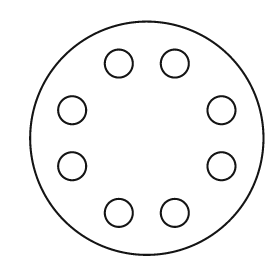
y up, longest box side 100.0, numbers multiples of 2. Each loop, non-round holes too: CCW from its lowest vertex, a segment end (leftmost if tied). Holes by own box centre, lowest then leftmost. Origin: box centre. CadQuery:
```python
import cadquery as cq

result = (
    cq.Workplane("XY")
    .moveTo(0.0, 0.0)
    .circle(50.0)
    .moveTo(-12.0, -32.0)
    .circle(6.0)
    .moveTo(12.0, -32.0)
    .circle(6.0)
    .moveTo(-32.0, -12.0)
    .circle(6.0)
    .moveTo(32.0, -12.0)
    .circle(6.0)
    .moveTo(-32.0, 12.0)
    .circle(6.0)
    .moveTo(32.0, 12.0)
    .circle(6.0)
    .moveTo(-12.0, 32.0)
    .circle(6.0)
    .moveTo(12.0, 32.0)
    .circle(6.0)
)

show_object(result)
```